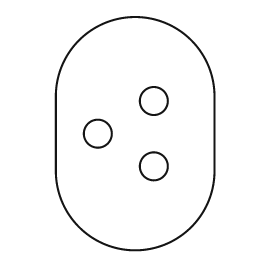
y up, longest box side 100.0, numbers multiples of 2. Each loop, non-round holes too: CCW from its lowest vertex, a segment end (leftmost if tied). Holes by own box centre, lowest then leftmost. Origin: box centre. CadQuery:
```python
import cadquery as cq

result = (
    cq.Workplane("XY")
    .moveTo(-34.0, -16.0)
    .threePointArc((0.0, -50.0), (34.0, -16.0))
    .lineTo(34.0, 16.0)
    .threePointArc((0.0, 50.0), (-34.0, 16.0))
    .close()
    .moveTo(8.0, -14.0)
    .circle(6.0)
    .moveTo(-16.0, 0.0)
    .circle(6.0)
    .moveTo(8.0, 14.0)
    .circle(6.0)
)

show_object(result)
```